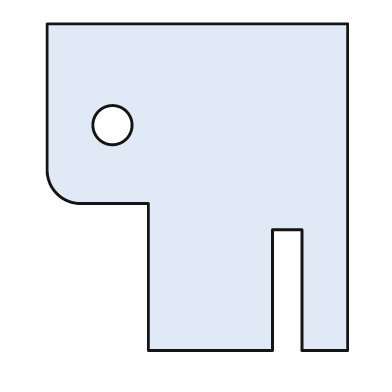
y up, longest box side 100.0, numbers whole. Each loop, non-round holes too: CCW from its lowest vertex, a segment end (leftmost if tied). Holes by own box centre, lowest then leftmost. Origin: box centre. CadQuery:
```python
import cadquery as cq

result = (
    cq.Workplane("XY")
    .moveTo(-15.0, -50.0)
    .lineTo(23.0, -50.0)
    .lineTo(23.0, -13.0)
    .lineTo(32.0, -13.0)
    .lineTo(32.0, -50.0)
    .lineTo(46.0, -50.0)
    .lineTo(46.0, 50.0)
    .lineTo(-46.0, 50.0)
    .lineTo(-46.0, 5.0)
    .threePointArc((-43.0, -2.0), (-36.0, -5.0))
    .lineTo(-15.0, -5.0)
    .close()
    .moveTo(-26.0, 19.0)
    .circle(6.0)
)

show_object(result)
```